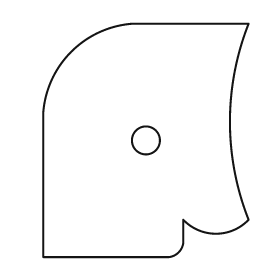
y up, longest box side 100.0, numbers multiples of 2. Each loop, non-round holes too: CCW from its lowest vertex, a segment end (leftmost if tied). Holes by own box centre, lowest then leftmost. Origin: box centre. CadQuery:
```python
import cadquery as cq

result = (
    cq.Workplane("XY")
    .moveTo(-44.0, -50.0)
    .lineTo(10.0, -50.0)
    .threePointArc((14.0, -48.0), (16.0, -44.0))
    .lineTo(16.0, -34.0)
    .threePointArc((30.0, -40.0), (44.0, -34.0))
    .threePointArc((36.0, 8.0), (44.0, 50.0))
    .lineTo(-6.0, 50.0)
    .threePointArc((-32.0, 38.0), (-44.0, 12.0))
    .close()
    .moveTo(0.0, 0.0)
    .circle(6.0)
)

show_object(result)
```